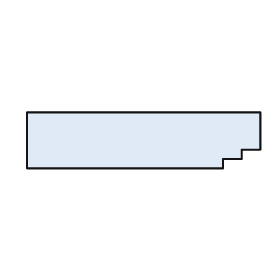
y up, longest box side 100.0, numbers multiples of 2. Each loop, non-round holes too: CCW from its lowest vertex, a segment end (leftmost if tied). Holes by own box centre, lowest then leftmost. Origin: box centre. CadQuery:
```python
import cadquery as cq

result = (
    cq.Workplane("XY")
    .moveTo(-50.0, -12.0)
    .lineTo(34.0, -12.0)
    .lineTo(34.0, -8.0)
    .lineTo(42.0, -8.0)
    .lineTo(42.0, -4.0)
    .lineTo(50.0, -4.0)
    .lineTo(50.0, 12.0)
    .lineTo(-50.0, 12.0)
    .close()
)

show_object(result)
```